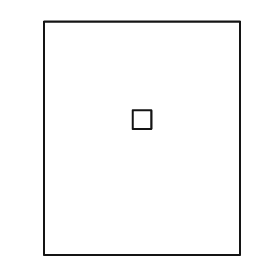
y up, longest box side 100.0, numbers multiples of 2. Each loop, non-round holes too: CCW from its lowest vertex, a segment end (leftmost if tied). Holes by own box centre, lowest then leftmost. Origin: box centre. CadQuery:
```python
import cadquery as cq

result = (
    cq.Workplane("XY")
    .moveTo(-42.0, -50.0)
    .lineTo(42.0, -50.0)
    .lineTo(42.0, 50.0)
    .lineTo(-42.0, 50.0)
    .close()
    .moveTo(-4.0, 4.0)
    .lineTo(4.0, 4.0)
    .lineTo(4.0, 12.0)
    .lineTo(-4.0, 12.0)
    .close()
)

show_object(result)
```